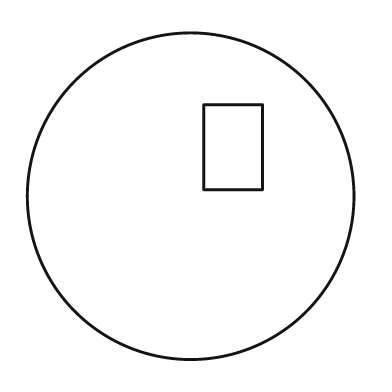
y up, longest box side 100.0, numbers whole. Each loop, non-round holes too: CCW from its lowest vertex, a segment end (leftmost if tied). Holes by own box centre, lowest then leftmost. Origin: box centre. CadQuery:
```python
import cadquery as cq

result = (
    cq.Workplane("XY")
    .moveTo(0.0, 0.0)
    .circle(50.0)
    .moveTo(4.0, 2.0)
    .lineTo(22.0, 2.0)
    .lineTo(22.0, 28.0)
    .lineTo(4.0, 28.0)
    .close()
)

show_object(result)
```